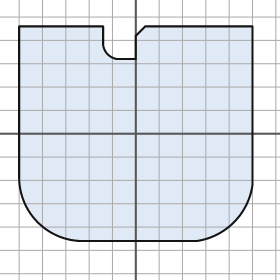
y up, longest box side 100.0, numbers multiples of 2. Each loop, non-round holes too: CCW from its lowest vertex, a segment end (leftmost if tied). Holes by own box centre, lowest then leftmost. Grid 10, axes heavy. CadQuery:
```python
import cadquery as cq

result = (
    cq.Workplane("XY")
    .moveTo(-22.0, -46.0)
    .lineTo(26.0, -46.0)
    .threePointArc((42.0, -38.0), (50.0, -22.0))
    .lineTo(50.0, 46.0)
    .lineTo(4.0, 46.0)
    .lineTo(0.0, 42.0)
    .lineTo(0.0, 32.0)
    .lineTo(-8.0, 32.0)
    .threePointArc((-12.0, 34.0), (-14.0, 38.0))
    .lineTo(-14.0, 46.0)
    .lineTo(-50.0, 46.0)
    .lineTo(-50.0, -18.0)
    .threePointArc((-42.0, -38.0), (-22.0, -46.0))
    .close()
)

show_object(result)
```